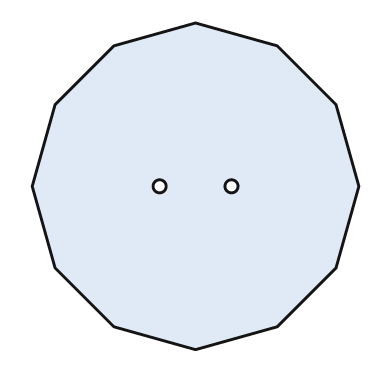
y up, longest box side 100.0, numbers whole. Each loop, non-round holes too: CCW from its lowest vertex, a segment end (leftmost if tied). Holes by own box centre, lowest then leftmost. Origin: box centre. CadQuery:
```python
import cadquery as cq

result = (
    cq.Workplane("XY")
    .moveTo(0.0, -50.0)
    .lineTo(25.0, -43.0)
    .lineTo(43.0, -25.0)
    .lineTo(50.0, 0.0)
    .lineTo(43.0, 25.0)
    .lineTo(25.0, 43.0)
    .lineTo(0.0, 50.0)
    .lineTo(-25.0, 43.0)
    .lineTo(-43.0, 25.0)
    .lineTo(-50.0, 0.0)
    .lineTo(-43.0, -25.0)
    .lineTo(-25.0, -43.0)
    .close()
    .moveTo(-11.0, 0.0)
    .circle(2.0)
    .moveTo(11.0, 0.0)
    .circle(2.0)
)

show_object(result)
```